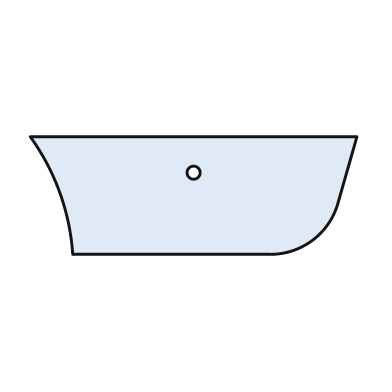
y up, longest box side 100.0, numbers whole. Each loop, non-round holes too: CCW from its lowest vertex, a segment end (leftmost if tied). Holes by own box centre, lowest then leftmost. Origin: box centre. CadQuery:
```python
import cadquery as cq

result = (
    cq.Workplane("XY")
    .moveTo(-37.0, -18.0)
    .lineTo(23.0, -18.0)
    .threePointArc((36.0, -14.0), (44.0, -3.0))
    .lineTo(50.0, 18.0)
    .lineTo(-50.0, 18.0)
    .threePointArc((-41.0, 1.0), (-37.0, -18.0))
    .close()
    .moveTo(0.0, 7.0)
    .circle(2.0)
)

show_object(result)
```